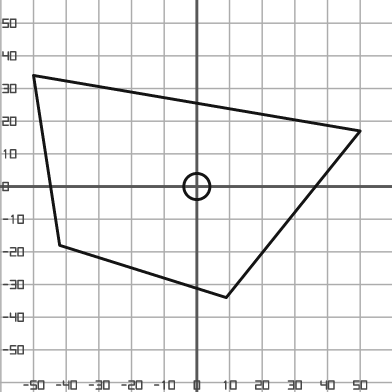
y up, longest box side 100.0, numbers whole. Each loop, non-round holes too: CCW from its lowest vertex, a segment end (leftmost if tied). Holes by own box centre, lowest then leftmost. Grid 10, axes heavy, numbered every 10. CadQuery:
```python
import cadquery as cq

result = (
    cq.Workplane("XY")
    .moveTo(9.0, -34.0)
    .lineTo(50.0, 17.0)
    .lineTo(-50.0, 34.0)
    .lineTo(-42.0, -18.0)
    .close()
    .moveTo(0.0, 0.0)
    .circle(4.0)
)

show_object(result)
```